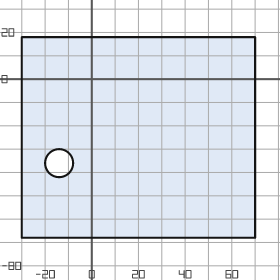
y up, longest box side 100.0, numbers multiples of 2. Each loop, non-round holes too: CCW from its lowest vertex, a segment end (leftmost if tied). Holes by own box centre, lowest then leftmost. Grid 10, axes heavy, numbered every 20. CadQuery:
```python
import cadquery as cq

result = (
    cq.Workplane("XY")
    .moveTo(-30.0, -68.0)
    .lineTo(70.0, -68.0)
    .lineTo(70.0, 18.0)
    .lineTo(-30.0, 18.0)
    .close()
    .moveTo(-14.0, -36.0)
    .circle(6.0)
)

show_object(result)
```